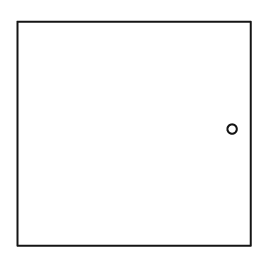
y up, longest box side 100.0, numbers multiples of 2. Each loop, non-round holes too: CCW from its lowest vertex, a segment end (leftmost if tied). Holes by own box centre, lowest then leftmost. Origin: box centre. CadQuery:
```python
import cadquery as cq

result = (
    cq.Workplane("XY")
    .moveTo(-50.0, -48.0)
    .lineTo(50.0, -48.0)
    .lineTo(50.0, 48.0)
    .lineTo(-50.0, 48.0)
    .close()
    .moveTo(42.0, 2.0)
    .circle(2.0)
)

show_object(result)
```